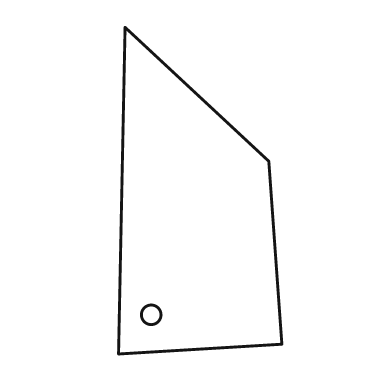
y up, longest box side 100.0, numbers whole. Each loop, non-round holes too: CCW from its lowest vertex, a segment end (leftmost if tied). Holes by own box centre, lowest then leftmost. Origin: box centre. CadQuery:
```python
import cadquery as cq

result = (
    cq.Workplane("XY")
    .moveTo(-25.0, -50.0)
    .lineTo(25.0, -47.0)
    .lineTo(21.0, 9.0)
    .lineTo(-23.0, 50.0)
    .close()
    .moveTo(-15.0, -38.0)
    .circle(3.0)
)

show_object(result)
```